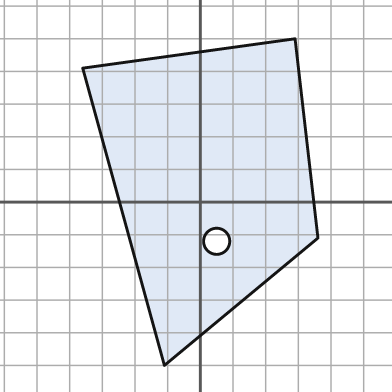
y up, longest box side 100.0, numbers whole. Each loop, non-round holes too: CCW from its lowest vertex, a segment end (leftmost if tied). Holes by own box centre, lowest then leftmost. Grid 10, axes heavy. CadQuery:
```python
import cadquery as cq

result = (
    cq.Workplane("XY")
    .moveTo(-11.0, -50.0)
    .lineTo(36.0, -11.0)
    .lineTo(29.0, 50.0)
    .lineTo(-36.0, 41.0)
    .close()
    .moveTo(5.0, -12.0)
    .circle(4.0)
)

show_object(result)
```